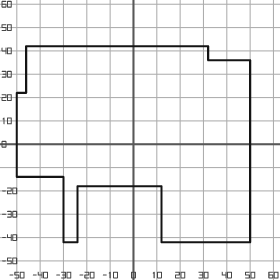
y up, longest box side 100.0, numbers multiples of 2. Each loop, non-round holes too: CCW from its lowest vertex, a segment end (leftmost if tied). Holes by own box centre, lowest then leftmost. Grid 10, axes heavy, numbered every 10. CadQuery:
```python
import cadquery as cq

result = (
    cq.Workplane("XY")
    .moveTo(-30.0, -42.0)
    .lineTo(-24.0, -42.0)
    .lineTo(-24.0, -18.0)
    .lineTo(12.0, -18.0)
    .lineTo(12.0, -42.0)
    .lineTo(50.0, -42.0)
    .lineTo(50.0, 36.0)
    .lineTo(32.0, 36.0)
    .lineTo(32.0, 42.0)
    .lineTo(-46.0, 42.0)
    .lineTo(-46.0, 22.0)
    .lineTo(-50.0, 22.0)
    .lineTo(-50.0, -14.0)
    .lineTo(-30.0, -14.0)
    .close()
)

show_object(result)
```